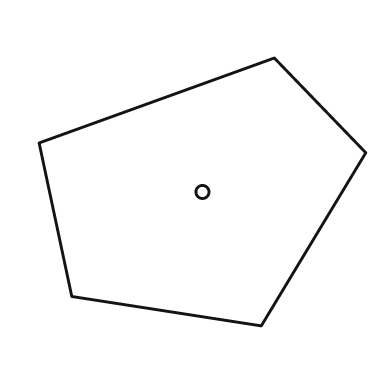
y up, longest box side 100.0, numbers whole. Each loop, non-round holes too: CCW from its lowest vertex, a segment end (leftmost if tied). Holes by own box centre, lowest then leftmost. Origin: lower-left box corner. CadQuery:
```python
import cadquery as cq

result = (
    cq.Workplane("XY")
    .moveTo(68.0, 0.0)
    .lineTo(100.0, 53.0)
    .lineTo(72.0, 82.0)
    .lineTo(0.0, 56.0)
    .lineTo(10.0, 9.0)
    .close()
    .moveTo(50.0, 41.0)
    .circle(2.0)
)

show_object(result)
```